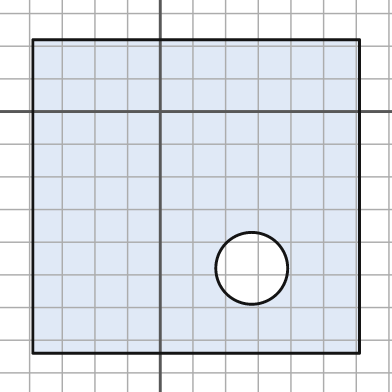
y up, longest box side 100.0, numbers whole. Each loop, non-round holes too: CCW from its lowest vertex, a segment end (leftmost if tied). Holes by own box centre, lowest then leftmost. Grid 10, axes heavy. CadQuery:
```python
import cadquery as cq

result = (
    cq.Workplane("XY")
    .moveTo(-39.0, -74.0)
    .lineTo(61.0, -74.0)
    .lineTo(61.0, 22.0)
    .lineTo(-39.0, 22.0)
    .close()
    .moveTo(28.0, -48.0)
    .circle(11.0)
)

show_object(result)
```